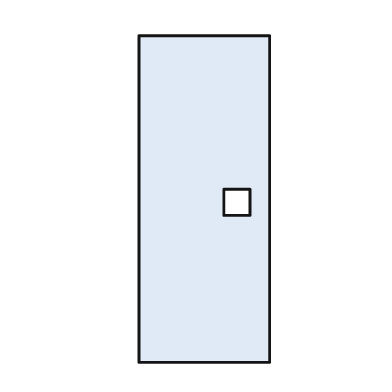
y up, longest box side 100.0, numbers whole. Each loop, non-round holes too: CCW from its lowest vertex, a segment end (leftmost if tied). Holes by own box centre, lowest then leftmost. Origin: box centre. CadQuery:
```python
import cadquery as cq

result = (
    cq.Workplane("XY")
    .moveTo(-20.0, -50.0)
    .lineTo(20.0, -50.0)
    .lineTo(20.0, 50.0)
    .lineTo(-20.0, 50.0)
    .close()
    .moveTo(6.0, -5.0)
    .lineTo(14.0, -5.0)
    .lineTo(14.0, 3.0)
    .lineTo(6.0, 3.0)
    .close()
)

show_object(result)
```